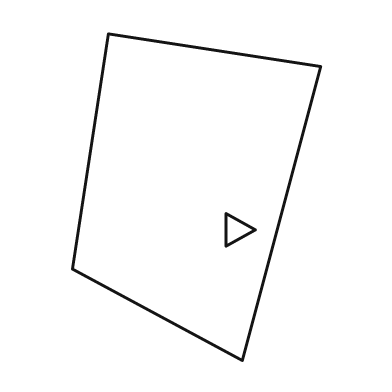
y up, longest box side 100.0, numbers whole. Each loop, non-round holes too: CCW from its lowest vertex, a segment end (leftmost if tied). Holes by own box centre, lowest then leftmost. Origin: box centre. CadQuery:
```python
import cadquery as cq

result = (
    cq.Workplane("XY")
    .moveTo(14.0, -50.0)
    .lineTo(38.0, 40.0)
    .lineTo(-27.0, 50.0)
    .lineTo(-38.0, -22.0)
    .close()
    .moveTo(9.0, -15.0)
    .lineTo(18.0, -10.0)
    .lineTo(9.0, -5.0)
    .close()
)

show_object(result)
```